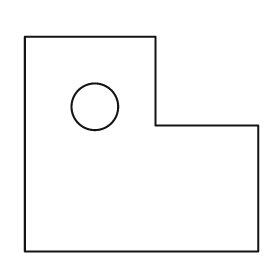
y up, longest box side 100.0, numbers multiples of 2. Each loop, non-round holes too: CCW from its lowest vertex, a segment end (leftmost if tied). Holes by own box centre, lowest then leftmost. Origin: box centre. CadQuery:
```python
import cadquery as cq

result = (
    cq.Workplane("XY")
    .moveTo(-50.0, -46.0)
    .lineTo(50.0, -46.0)
    .lineTo(50.0, 8.0)
    .lineTo(6.0, 8.0)
    .lineTo(6.0, 46.0)
    .lineTo(-50.0, 46.0)
    .close()
    .moveTo(-20.0, 16.0)
    .circle(10.0)
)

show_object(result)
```